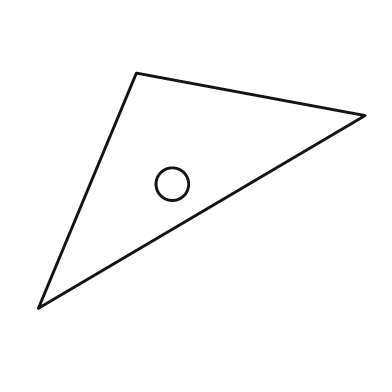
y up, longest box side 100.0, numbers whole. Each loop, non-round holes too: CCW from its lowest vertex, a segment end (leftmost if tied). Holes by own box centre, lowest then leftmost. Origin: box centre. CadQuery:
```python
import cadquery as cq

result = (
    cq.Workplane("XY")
    .moveTo(-50.0, -36.0)
    .lineTo(50.0, 23.0)
    .lineTo(-20.0, 36.0)
    .close()
    .moveTo(-9.0, 2.0)
    .circle(5.0)
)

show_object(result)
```